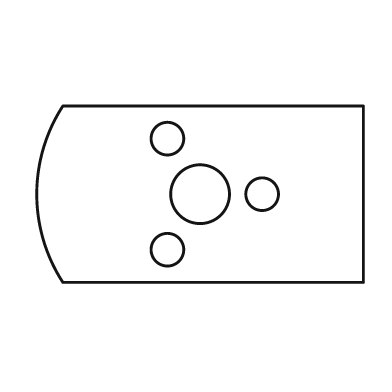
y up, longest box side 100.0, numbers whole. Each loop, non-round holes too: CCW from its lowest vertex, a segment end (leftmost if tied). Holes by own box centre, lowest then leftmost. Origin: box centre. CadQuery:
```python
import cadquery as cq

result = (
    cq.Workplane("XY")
    .moveTo(-42.0, -27.0)
    .lineTo(50.0, -27.0)
    .lineTo(50.0, 27.0)
    .lineTo(-42.0, 27.0)
    .threePointArc((-50.0, 0.0), (-42.0, -27.0))
    .close()
    .moveTo(-10.0, -17.0)
    .circle(5.0)
    .moveTo(0.0, 0.0)
    .circle(9.0)
    .moveTo(19.0, 0.0)
    .circle(5.0)
    .moveTo(-10.0, 17.0)
    .circle(5.0)
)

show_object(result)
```